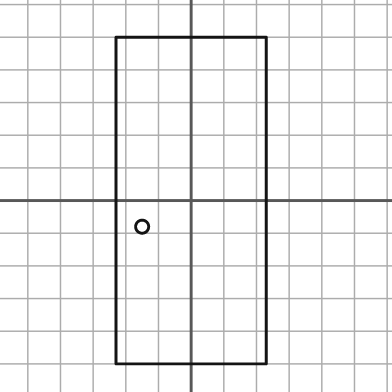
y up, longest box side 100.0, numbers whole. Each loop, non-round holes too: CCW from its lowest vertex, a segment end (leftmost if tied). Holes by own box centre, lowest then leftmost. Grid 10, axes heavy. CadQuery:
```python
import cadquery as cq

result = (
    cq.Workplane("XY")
    .moveTo(-23.0, -50.0)
    .lineTo(23.0, -50.0)
    .lineTo(23.0, 50.0)
    .lineTo(-23.0, 50.0)
    .close()
    .moveTo(-15.0, -8.0)
    .circle(2.0)
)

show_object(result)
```